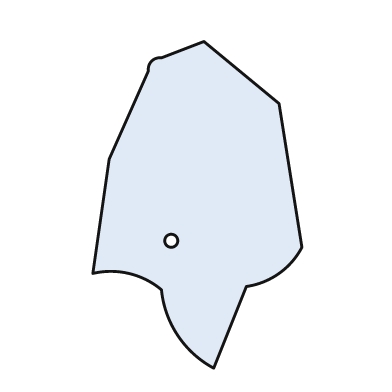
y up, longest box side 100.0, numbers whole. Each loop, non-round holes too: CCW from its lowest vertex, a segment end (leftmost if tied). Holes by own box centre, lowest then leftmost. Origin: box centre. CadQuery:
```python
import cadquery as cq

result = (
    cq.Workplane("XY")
    .moveTo(5.0, -50.0)
    .lineTo(15.0, -25.0)
    .threePointArc((25.0, -21.0), (32.0, -13.0))
    .lineTo(25.0, 31.0)
    .lineTo(2.0, 50.0)
    .lineTo(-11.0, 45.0)
    .threePointArc((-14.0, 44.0), (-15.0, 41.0))
    .lineTo(-27.0, 14.0)
    .lineTo(-32.0, -21.0)
    .threePointArc((-21.0, -21.0), (-11.0, -26.0))
    .threePointArc((-6.0, -40.0), (5.0, -50.0))
    .close()
    .moveTo(-8.0, -11.0)
    .circle(2.0)
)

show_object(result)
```